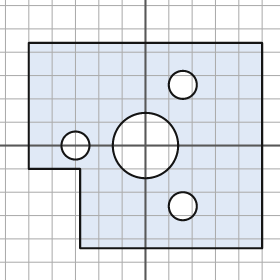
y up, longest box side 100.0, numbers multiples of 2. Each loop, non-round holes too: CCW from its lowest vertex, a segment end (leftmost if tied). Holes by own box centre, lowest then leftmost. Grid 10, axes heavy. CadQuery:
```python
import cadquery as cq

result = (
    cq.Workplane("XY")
    .moveTo(-28.0, -44.0)
    .lineTo(50.0, -44.0)
    .lineTo(50.0, 44.0)
    .lineTo(-50.0, 44.0)
    .lineTo(-50.0, -10.0)
    .lineTo(-28.0, -10.0)
    .close()
    .moveTo(16.0, -26.0)
    .circle(6.0)
    .moveTo(-30.0, 0.0)
    .circle(6.0)
    .moveTo(0.0, 0.0)
    .circle(14.0)
    .moveTo(16.0, 26.0)
    .circle(6.0)
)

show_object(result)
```